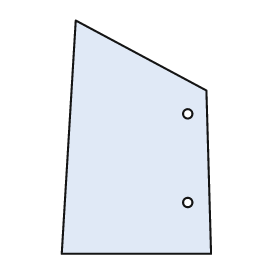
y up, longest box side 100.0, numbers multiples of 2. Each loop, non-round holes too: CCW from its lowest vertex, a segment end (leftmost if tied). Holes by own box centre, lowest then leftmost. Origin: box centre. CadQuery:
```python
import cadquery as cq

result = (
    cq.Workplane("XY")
    .moveTo(-32.0, -50.0)
    .lineTo(32.0, -50.0)
    .lineTo(30.0, 20.0)
    .lineTo(-26.0, 50.0)
    .close()
    .moveTo(22.0, -28.0)
    .circle(2.0)
    .moveTo(22.0, 10.0)
    .circle(2.0)
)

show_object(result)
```